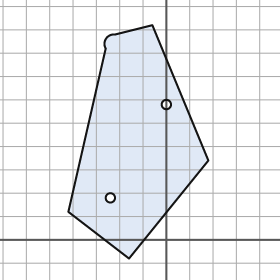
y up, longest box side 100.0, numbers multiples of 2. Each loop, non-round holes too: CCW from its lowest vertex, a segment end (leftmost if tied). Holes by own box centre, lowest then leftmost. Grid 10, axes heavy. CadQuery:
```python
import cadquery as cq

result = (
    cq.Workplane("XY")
    .moveTo(-16.0, -8.0)
    .lineTo(18.0, 34.0)
    .lineTo(-6.0, 92.0)
    .lineTo(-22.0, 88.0)
    .threePointArc((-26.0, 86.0), (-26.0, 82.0))
    .lineTo(-42.0, 12.0)
    .close()
    .moveTo(-24.0, 18.0)
    .circle(2.0)
    .moveTo(0.0, 58.0)
    .circle(2.0)
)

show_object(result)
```